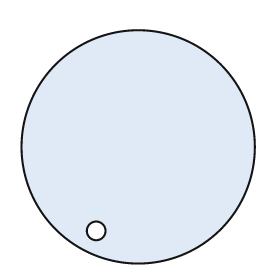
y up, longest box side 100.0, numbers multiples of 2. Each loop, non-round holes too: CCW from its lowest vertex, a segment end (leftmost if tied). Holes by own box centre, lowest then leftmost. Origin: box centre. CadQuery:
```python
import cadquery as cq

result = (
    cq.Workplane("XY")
    .moveTo(0.0, 0.0)
    .circle(50.0)
    .moveTo(-18.0, -36.0)
    .circle(4.0)
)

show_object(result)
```